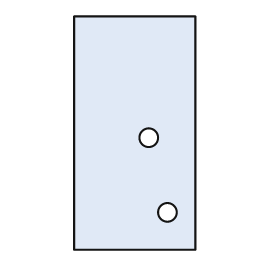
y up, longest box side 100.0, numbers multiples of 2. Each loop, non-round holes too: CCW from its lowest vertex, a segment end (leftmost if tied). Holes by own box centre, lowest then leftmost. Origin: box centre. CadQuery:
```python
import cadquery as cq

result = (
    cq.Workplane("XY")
    .moveTo(-26.0, -50.0)
    .lineTo(26.0, -50.0)
    .lineTo(26.0, 50.0)
    .lineTo(-26.0, 50.0)
    .close()
    .moveTo(14.0, -34.0)
    .circle(4.0)
    .moveTo(6.0, -2.0)
    .circle(4.0)
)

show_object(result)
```